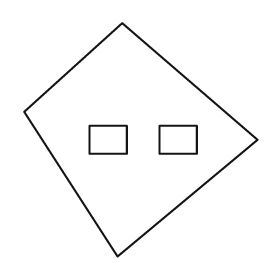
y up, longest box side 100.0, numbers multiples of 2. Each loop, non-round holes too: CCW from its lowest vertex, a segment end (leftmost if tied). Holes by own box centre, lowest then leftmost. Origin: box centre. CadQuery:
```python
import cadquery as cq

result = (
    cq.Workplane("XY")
    .moveTo(-10.0, -50.0)
    .lineTo(50.0, 0.0)
    .lineTo(-8.0, 50.0)
    .lineTo(-50.0, 12.0)
    .close()
    .moveTo(-22.0, -6.0)
    .lineTo(-6.0, -6.0)
    .lineTo(-6.0, 6.0)
    .lineTo(-22.0, 6.0)
    .close()
    .moveTo(8.0, -6.0)
    .lineTo(24.0, -6.0)
    .lineTo(24.0, 6.0)
    .lineTo(8.0, 6.0)
    .close()
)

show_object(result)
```